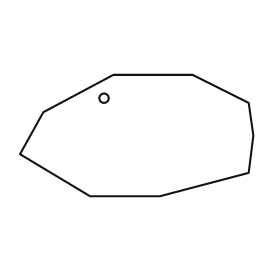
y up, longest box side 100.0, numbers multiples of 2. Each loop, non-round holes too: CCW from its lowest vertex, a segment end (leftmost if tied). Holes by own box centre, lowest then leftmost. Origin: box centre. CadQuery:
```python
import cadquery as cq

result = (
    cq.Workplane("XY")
    .moveTo(-20.0, -26.0)
    .lineTo(10.0, -26.0)
    .lineTo(48.0, -16.0)
    .lineTo(50.0, 0.0)
    .lineTo(48.0, 14.0)
    .lineTo(24.0, 26.0)
    .lineTo(-10.0, 26.0)
    .lineTo(-40.0, 10.0)
    .lineTo(-50.0, -8.0)
    .close()
    .moveTo(-14.0, 16.0)
    .circle(2.0)
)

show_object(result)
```